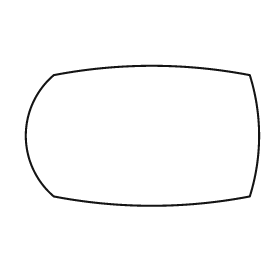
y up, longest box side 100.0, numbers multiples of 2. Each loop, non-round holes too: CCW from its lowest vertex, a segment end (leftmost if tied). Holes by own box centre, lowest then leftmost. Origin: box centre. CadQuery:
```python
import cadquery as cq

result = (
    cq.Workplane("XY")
    .moveTo(-38.0, -26.0)
    .threePointArc((4.0, -30.0), (46.0, -26.0))
    .threePointArc((50.0, 0.0), (46.0, 26.0))
    .threePointArc((4.0, 30.0), (-38.0, 26.0))
    .threePointArc((-50.0, 0.0), (-38.0, -26.0))
    .close()
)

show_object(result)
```